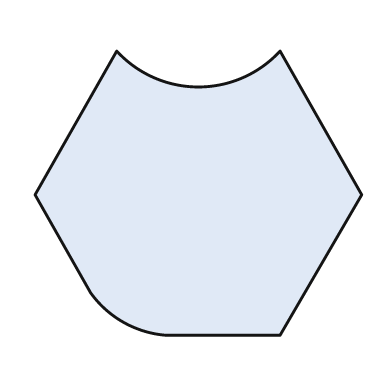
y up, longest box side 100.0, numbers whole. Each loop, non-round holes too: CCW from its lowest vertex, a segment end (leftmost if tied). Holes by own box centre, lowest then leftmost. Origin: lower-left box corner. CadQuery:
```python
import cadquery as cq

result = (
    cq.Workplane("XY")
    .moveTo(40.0, 0.0)
    .lineTo(75.0, 0.0)
    .lineTo(100.0, 43.0)
    .lineTo(75.0, 87.0)
    .threePointArc((50.0, 76.0), (25.0, 87.0))
    .lineTo(0.0, 43.0)
    .lineTo(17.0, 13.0)
    .threePointArc((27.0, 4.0), (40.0, 0.0))
    .close()
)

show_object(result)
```